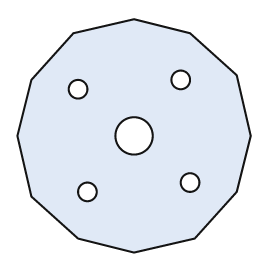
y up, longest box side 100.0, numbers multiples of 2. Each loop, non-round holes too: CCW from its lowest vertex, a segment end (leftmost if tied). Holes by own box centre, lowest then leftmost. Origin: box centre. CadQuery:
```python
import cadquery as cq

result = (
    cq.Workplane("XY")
    .moveTo(0.0, -50.0)
    .lineTo(26.0, -44.0)
    .lineTo(44.0, -24.0)
    .lineTo(50.0, 0.0)
    .lineTo(44.0, 26.0)
    .lineTo(24.0, 44.0)
    .lineTo(0.0, 50.0)
    .lineTo(-26.0, 44.0)
    .lineTo(-44.0, 24.0)
    .lineTo(-50.0, 0.0)
    .lineTo(-44.0, -26.0)
    .lineTo(-24.0, -44.0)
    .close()
    .moveTo(-20.0, -24.0)
    .circle(4.0)
    .moveTo(24.0, -20.0)
    .circle(4.0)
    .moveTo(0.0, 0.0)
    .circle(8.0)
    .moveTo(-24.0, 20.0)
    .circle(4.0)
    .moveTo(20.0, 24.0)
    .circle(4.0)
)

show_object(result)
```